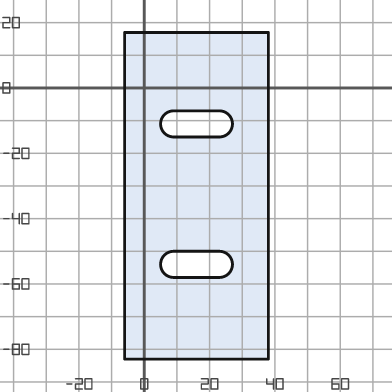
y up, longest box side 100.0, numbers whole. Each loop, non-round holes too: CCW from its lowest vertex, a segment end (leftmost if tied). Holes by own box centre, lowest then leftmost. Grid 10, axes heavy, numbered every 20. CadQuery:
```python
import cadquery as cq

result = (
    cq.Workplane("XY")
    .moveTo(-6.0, -83.0)
    .lineTo(38.0, -83.0)
    .lineTo(38.0, 17.0)
    .lineTo(-6.0, 17.0)
    .close()
    .moveTo(9.0, -58.0)
    .lineTo(23.0, -58.0)
    .threePointArc((27.0, -54.0), (23.0, -50.0))
    .lineTo(9.0, -50.0)
    .threePointArc((5.0, -54.0), (9.0, -58.0))
    .close()
    .moveTo(9.0, -15.0)
    .lineTo(23.0, -15.0)
    .threePointArc((27.0, -11.0), (23.0, -7.0))
    .lineTo(9.0, -7.0)
    .threePointArc((5.0, -11.0), (9.0, -15.0))
    .close()
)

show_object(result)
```